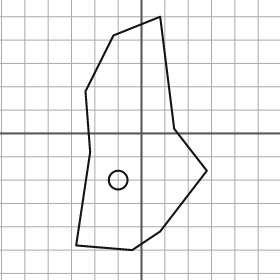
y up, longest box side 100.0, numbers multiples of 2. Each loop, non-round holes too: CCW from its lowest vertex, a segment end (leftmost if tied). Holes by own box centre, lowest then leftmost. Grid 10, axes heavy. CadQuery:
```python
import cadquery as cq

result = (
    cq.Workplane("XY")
    .moveTo(-4.0, -50.0)
    .lineTo(8.0, -42.0)
    .lineTo(28.0, -16.0)
    .lineTo(14.0, 2.0)
    .lineTo(8.0, 50.0)
    .lineTo(-12.0, 42.0)
    .lineTo(-24.0, 18.0)
    .lineTo(-22.0, -8.0)
    .lineTo(-28.0, -48.0)
    .close()
    .moveTo(-10.0, -20.0)
    .circle(4.0)
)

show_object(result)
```